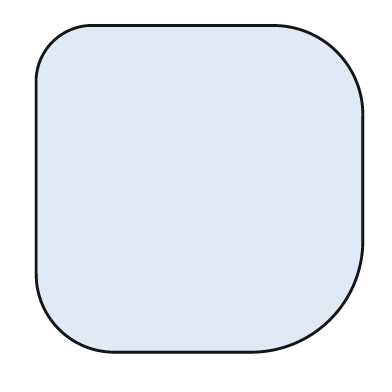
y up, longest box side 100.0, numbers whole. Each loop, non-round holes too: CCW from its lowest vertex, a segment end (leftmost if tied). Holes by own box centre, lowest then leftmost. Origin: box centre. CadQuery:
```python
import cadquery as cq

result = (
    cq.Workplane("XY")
    .moveTo(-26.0, -50.0)
    .lineTo(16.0, -50.0)
    .threePointArc((40.0, -40.0), (50.0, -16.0))
    .lineTo(50.0, 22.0)
    .threePointArc((42.0, 42.0), (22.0, 50.0))
    .lineTo(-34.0, 50.0)
    .threePointArc((-45.0, 45.0), (-50.0, 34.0))
    .lineTo(-50.0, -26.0)
    .threePointArc((-43.0, -43.0), (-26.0, -50.0))
    .close()
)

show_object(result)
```